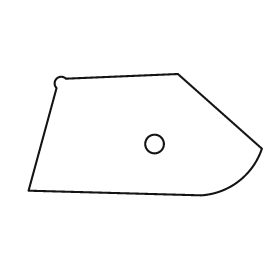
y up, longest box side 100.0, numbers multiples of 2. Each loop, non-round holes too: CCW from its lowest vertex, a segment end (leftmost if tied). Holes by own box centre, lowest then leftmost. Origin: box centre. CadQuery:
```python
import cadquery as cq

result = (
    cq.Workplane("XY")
    .moveTo(24.0, -26.0)
    .threePointArc((40.0, -20.0), (50.0, -6.0))
    .lineTo(14.0, 26.0)
    .lineTo(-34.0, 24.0)
    .threePointArc((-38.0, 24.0), (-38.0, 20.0))
    .lineTo(-50.0, -24.0)
    .close()
    .moveTo(4.0, -4.0)
    .circle(4.0)
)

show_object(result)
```